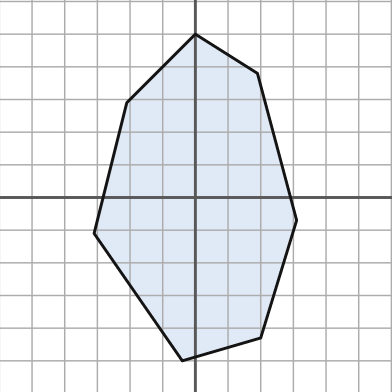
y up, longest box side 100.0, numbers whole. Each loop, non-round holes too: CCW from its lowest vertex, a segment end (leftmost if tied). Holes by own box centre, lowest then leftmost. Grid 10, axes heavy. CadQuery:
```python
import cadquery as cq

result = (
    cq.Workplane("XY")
    .moveTo(-4.0, -50.0)
    .lineTo(20.0, -43.0)
    .lineTo(31.0, -7.0)
    .lineTo(19.0, 38.0)
    .lineTo(0.0, 50.0)
    .lineTo(-21.0, 29.0)
    .lineTo(-31.0, -11.0)
    .close()
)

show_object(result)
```